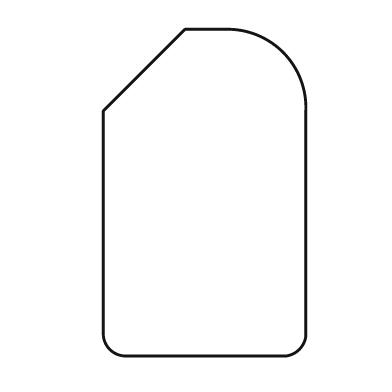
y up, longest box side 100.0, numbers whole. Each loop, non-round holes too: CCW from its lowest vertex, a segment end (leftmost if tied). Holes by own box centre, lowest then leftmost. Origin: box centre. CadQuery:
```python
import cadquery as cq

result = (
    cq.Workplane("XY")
    .moveTo(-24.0, -50.0)
    .lineTo(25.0, -50.0)
    .threePointArc((29.0, -48.0), (31.0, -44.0))
    .lineTo(31.0, 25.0)
    .threePointArc((24.0, 43.0), (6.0, 50.0))
    .lineTo(-6.0, 50.0)
    .lineTo(-31.0, 25.0)
    .lineTo(-31.0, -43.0)
    .threePointArc((-29.0, -48.0), (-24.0, -50.0))
    .close()
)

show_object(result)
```